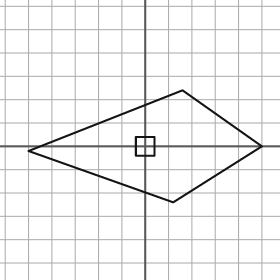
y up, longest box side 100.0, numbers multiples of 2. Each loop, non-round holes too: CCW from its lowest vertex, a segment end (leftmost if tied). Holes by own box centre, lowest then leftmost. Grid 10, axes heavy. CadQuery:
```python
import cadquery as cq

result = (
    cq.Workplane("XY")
    .moveTo(12.0, -24.0)
    .lineTo(50.0, 0.0)
    .lineTo(16.0, 24.0)
    .lineTo(-50.0, -2.0)
    .close()
    .moveTo(-4.0, -4.0)
    .lineTo(4.0, -4.0)
    .lineTo(4.0, 4.0)
    .lineTo(-4.0, 4.0)
    .close()
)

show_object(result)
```